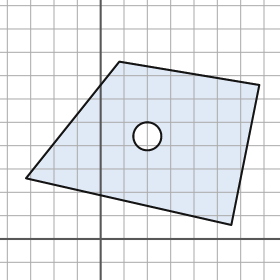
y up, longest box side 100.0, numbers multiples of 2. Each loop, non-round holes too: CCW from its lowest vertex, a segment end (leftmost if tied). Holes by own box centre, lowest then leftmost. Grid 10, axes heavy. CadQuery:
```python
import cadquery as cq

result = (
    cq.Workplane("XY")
    .moveTo(56.0, 6.0)
    .lineTo(68.0, 66.0)
    .lineTo(8.0, 76.0)
    .lineTo(-32.0, 26.0)
    .close()
    .moveTo(20.0, 44.0)
    .circle(6.0)
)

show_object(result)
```